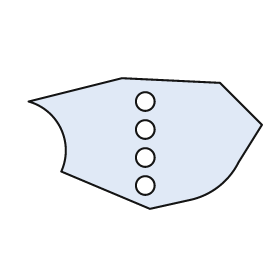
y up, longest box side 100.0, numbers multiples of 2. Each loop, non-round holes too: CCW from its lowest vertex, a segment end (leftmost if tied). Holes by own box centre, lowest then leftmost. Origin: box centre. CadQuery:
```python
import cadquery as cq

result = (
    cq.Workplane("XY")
    .moveTo(2.0, -28.0)
    .lineTo(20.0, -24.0)
    .threePointArc((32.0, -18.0), (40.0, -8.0))
    .lineTo(50.0, 8.0)
    .lineTo(32.0, 26.0)
    .lineTo(-10.0, 28.0)
    .lineTo(-50.0, 18.0)
    .threePointArc((-36.0, 6.0), (-36.0, -12.0))
    .close()
    .moveTo(0.0, -18.0)
    .circle(4.0)
    .moveTo(0.0, -6.0)
    .circle(4.0)
    .moveTo(0.0, 6.0)
    .circle(4.0)
    .moveTo(0.0, 18.0)
    .circle(4.0)
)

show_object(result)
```